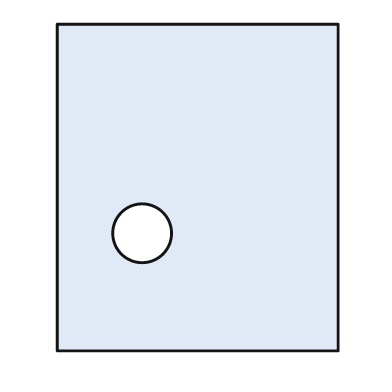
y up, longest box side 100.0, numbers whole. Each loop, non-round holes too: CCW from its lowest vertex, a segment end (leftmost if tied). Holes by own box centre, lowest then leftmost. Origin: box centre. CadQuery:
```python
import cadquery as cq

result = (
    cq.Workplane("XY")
    .moveTo(-43.0, -50.0)
    .lineTo(43.0, -50.0)
    .lineTo(43.0, 50.0)
    .lineTo(-43.0, 50.0)
    .close()
    .moveTo(-17.0, -14.0)
    .circle(9.0)
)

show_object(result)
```